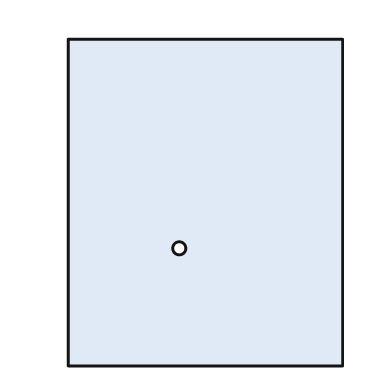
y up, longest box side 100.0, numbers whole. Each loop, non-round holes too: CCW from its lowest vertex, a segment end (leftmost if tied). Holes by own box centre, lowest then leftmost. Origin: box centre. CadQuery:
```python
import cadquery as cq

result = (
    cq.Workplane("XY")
    .moveTo(-42.0, -50.0)
    .lineTo(42.0, -50.0)
    .lineTo(42.0, 50.0)
    .lineTo(-42.0, 50.0)
    .close()
    .moveTo(-8.0, -14.0)
    .circle(2.0)
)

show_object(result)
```